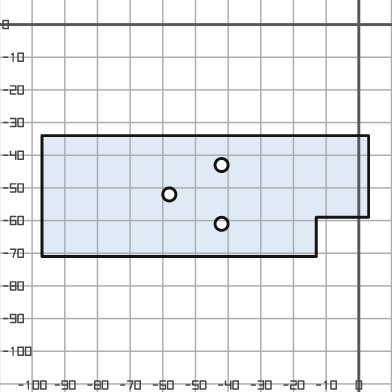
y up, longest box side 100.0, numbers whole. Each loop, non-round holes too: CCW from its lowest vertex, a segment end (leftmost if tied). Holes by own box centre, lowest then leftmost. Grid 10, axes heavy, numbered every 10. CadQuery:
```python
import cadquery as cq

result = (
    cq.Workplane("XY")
    .moveTo(-97.0, -71.0)
    .lineTo(-13.0, -71.0)
    .lineTo(-13.0, -59.0)
    .lineTo(3.0, -59.0)
    .lineTo(3.0, -34.0)
    .lineTo(-97.0, -34.0)
    .close()
    .moveTo(-42.0, -61.0)
    .circle(2.0)
    .moveTo(-58.0, -52.0)
    .circle(2.0)
    .moveTo(-42.0, -43.0)
    .circle(2.0)
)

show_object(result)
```